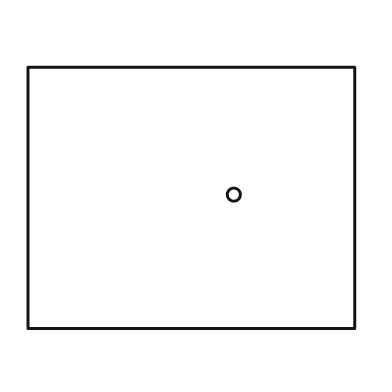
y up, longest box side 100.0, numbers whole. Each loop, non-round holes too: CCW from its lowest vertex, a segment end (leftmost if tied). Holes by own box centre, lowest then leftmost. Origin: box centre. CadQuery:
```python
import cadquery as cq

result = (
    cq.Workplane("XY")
    .moveTo(-50.0, -40.0)
    .lineTo(50.0, -40.0)
    .lineTo(50.0, 40.0)
    .lineTo(-50.0, 40.0)
    .close()
    .moveTo(13.0, 1.0)
    .circle(2.0)
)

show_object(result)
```